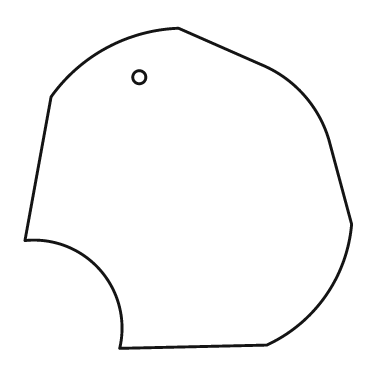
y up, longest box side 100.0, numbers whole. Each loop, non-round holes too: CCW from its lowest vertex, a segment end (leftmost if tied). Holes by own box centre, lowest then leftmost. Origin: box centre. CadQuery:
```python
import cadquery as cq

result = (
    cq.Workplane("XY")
    .moveTo(-21.0, -49.0)
    .lineTo(24.0, -48.0)
    .threePointArc((42.0, -33.0), (50.0, -11.0))
    .lineTo(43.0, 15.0)
    .threePointArc((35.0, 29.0), (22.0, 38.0))
    .lineTo(-3.0, 49.0)
    .threePointArc((-25.0, 43.0), (-42.0, 28.0))
    .lineTo(-50.0, -16.0)
    .threePointArc((-27.0, -25.0), (-21.0, -49.0))
    .close()
    .moveTo(-15.0, 34.0)
    .circle(2.0)
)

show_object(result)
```